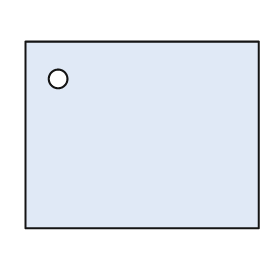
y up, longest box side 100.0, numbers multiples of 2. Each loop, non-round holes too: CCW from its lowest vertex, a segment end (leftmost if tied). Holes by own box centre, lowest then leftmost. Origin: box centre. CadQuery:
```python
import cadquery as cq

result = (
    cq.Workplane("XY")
    .moveTo(-50.0, -40.0)
    .lineTo(50.0, -40.0)
    .lineTo(50.0, 40.0)
    .lineTo(-50.0, 40.0)
    .close()
    .moveTo(-36.0, 24.0)
    .circle(4.0)
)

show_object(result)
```